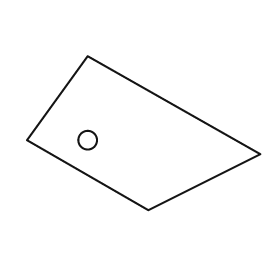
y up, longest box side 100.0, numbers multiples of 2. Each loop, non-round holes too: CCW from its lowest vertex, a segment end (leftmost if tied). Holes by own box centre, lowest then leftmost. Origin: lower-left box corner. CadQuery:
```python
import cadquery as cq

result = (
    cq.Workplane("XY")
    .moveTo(52.0, 0.0)
    .lineTo(100.0, 24.0)
    .lineTo(26.0, 66.0)
    .lineTo(0.0, 30.0)
    .close()
    .moveTo(26.0, 30.0)
    .circle(4.0)
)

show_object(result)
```